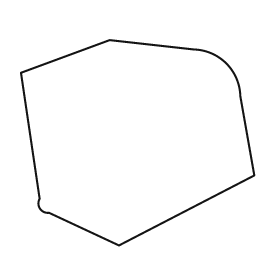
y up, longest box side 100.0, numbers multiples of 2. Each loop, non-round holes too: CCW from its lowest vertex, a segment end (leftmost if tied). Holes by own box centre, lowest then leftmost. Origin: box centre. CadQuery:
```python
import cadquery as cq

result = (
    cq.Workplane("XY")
    .moveTo(-8.0, -44.0)
    .lineTo(50.0, -14.0)
    .lineTo(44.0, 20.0)
    .threePointArc((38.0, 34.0), (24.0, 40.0))
    .lineTo(-12.0, 44.0)
    .lineTo(-50.0, 30.0)
    .lineTo(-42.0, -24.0)
    .threePointArc((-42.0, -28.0), (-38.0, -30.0))
    .close()
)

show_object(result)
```